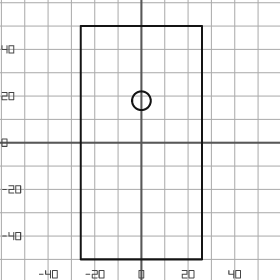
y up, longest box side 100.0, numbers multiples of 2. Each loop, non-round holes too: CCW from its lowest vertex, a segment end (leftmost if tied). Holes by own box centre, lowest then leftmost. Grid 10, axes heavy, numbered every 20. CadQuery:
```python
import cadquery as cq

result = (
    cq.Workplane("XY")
    .moveTo(-26.0, -50.0)
    .lineTo(26.0, -50.0)
    .lineTo(26.0, 50.0)
    .lineTo(-26.0, 50.0)
    .close()
    .moveTo(0.0, 18.0)
    .circle(4.0)
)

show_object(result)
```